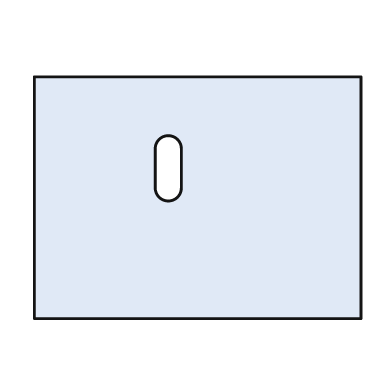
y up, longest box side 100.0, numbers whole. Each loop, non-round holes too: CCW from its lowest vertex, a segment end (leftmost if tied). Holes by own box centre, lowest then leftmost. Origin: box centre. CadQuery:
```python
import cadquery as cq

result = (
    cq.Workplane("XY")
    .moveTo(-50.0, -37.0)
    .lineTo(50.0, -37.0)
    .lineTo(50.0, 37.0)
    .lineTo(-50.0, 37.0)
    .close()
    .moveTo(-13.0, 3.0)
    .threePointArc((-9.0, -1.0), (-5.0, 3.0))
    .lineTo(-5.0, 15.0)
    .threePointArc((-9.0, 19.0), (-13.0, 15.0))
    .close()
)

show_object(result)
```